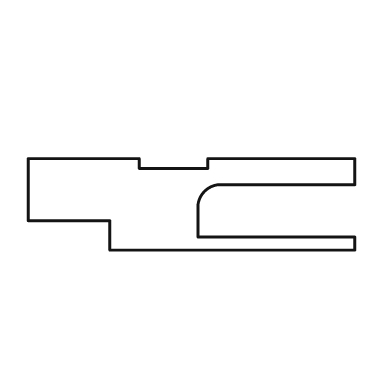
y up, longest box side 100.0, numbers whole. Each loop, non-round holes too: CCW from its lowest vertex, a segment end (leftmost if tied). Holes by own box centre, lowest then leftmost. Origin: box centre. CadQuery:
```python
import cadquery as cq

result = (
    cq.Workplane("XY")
    .moveTo(-25.0, -14.0)
    .lineTo(50.0, -14.0)
    .lineTo(50.0, -10.0)
    .lineTo(2.0, -10.0)
    .lineTo(2.0, 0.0)
    .threePointArc((4.0, 4.0), (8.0, 6.0))
    .lineTo(50.0, 6.0)
    .lineTo(50.0, 14.0)
    .lineTo(5.0, 14.0)
    .lineTo(5.0, 11.0)
    .lineTo(-16.0, 11.0)
    .lineTo(-16.0, 14.0)
    .lineTo(-50.0, 14.0)
    .lineTo(-50.0, -5.0)
    .lineTo(-25.0, -5.0)
    .close()
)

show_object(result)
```